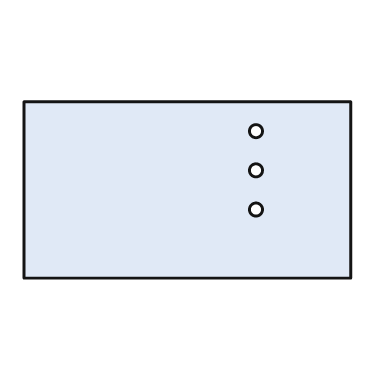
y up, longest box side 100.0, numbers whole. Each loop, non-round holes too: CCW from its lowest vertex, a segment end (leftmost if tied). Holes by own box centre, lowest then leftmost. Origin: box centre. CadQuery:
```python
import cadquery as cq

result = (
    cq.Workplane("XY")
    .moveTo(-50.0, -27.0)
    .lineTo(50.0, -27.0)
    .lineTo(50.0, 27.0)
    .lineTo(-50.0, 27.0)
    .close()
    .moveTo(21.0, -6.0)
    .circle(2.0)
    .moveTo(21.0, 6.0)
    .circle(2.0)
    .moveTo(21.0, 18.0)
    .circle(2.0)
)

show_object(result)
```